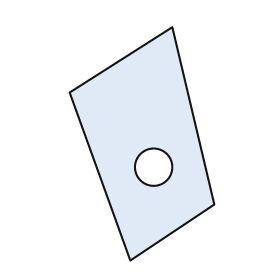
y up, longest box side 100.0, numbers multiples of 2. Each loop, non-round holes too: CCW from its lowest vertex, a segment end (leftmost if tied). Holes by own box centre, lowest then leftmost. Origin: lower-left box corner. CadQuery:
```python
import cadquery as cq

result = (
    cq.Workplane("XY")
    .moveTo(26.0, 0.0)
    .lineTo(62.0, 24.0)
    .lineTo(44.0, 100.0)
    .lineTo(0.0, 72.0)
    .close()
    .moveTo(36.0, 40.0)
    .circle(8.0)
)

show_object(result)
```